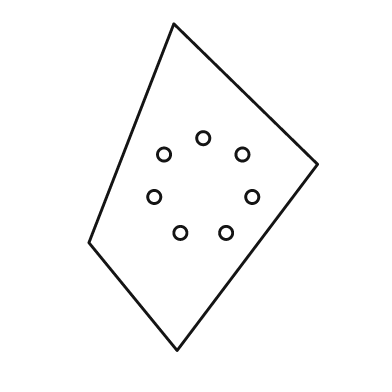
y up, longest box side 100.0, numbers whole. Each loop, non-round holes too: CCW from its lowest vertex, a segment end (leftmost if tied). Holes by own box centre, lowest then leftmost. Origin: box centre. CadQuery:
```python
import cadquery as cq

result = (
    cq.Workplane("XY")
    .moveTo(-8.0, -50.0)
    .lineTo(35.0, 7.0)
    .lineTo(-9.0, 50.0)
    .lineTo(-35.0, -17.0)
    .close()
    .moveTo(-7.0, -14.0)
    .circle(2.0)
    .moveTo(7.0, -14.0)
    .circle(2.0)
    .moveTo(-15.0, -3.0)
    .circle(2.0)
    .moveTo(15.0, -3.0)
    .circle(2.0)
    .moveTo(-12.0, 10.0)
    .circle(2.0)
    .moveTo(12.0, 10.0)
    .circle(2.0)
    .moveTo(0.0, 15.0)
    .circle(2.0)
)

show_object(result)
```